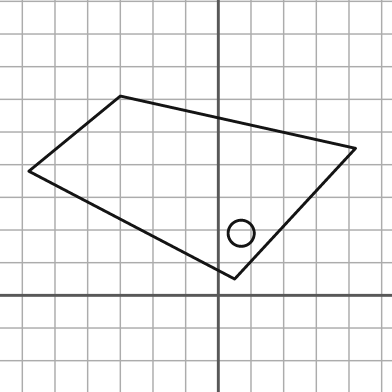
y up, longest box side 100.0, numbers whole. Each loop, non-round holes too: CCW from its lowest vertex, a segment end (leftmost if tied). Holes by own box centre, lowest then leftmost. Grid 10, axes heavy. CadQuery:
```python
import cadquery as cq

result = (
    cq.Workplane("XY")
    .moveTo(5.0, 5.0)
    .lineTo(42.0, 45.0)
    .lineTo(-30.0, 61.0)
    .lineTo(-58.0, 38.0)
    .close()
    .moveTo(7.0, 19.0)
    .circle(4.0)
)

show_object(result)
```